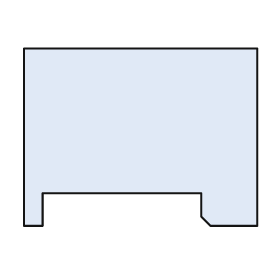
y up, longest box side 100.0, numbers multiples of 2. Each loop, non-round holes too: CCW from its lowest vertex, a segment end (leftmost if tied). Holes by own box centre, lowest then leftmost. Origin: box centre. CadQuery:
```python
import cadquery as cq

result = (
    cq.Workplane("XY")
    .moveTo(-50.0, -38.0)
    .lineTo(-42.0, -38.0)
    .lineTo(-42.0, -24.0)
    .lineTo(26.0, -24.0)
    .lineTo(26.0, -34.0)
    .lineTo(30.0, -38.0)
    .lineTo(50.0, -38.0)
    .lineTo(50.0, 38.0)
    .lineTo(-50.0, 38.0)
    .close()
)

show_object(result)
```